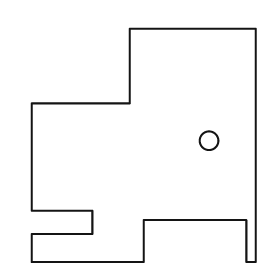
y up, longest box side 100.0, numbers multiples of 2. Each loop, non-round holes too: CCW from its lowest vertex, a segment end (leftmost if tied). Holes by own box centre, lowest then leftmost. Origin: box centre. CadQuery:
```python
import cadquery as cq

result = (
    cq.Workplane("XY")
    .moveTo(-48.0, -50.0)
    .lineTo(0.0, -50.0)
    .lineTo(0.0, -32.0)
    .lineTo(44.0, -32.0)
    .lineTo(44.0, -50.0)
    .lineTo(48.0, -50.0)
    .lineTo(48.0, 50.0)
    .lineTo(-6.0, 50.0)
    .lineTo(-6.0, 18.0)
    .lineTo(-48.0, 18.0)
    .lineTo(-48.0, -28.0)
    .lineTo(-22.0, -28.0)
    .lineTo(-22.0, -38.0)
    .lineTo(-48.0, -38.0)
    .close()
    .moveTo(28.0, 2.0)
    .circle(4.0)
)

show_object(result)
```